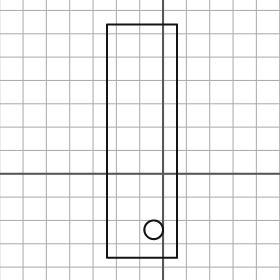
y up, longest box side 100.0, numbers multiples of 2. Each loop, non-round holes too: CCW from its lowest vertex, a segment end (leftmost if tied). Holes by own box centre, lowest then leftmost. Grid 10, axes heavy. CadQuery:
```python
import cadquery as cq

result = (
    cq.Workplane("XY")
    .moveTo(-24.0, -36.0)
    .lineTo(6.0, -36.0)
    .lineTo(6.0, 64.0)
    .lineTo(-24.0, 64.0)
    .close()
    .moveTo(-4.0, -24.0)
    .circle(4.0)
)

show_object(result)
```